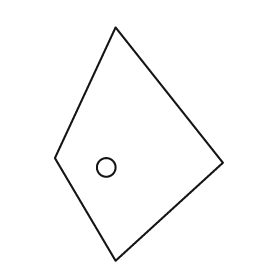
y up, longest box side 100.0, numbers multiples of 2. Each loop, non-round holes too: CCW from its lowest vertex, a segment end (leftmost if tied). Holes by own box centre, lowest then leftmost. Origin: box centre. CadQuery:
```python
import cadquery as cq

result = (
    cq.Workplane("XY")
    .moveTo(-10.0, -50.0)
    .lineTo(36.0, -8.0)
    .lineTo(-10.0, 50.0)
    .lineTo(-36.0, -6.0)
    .close()
    .moveTo(-14.0, -10.0)
    .circle(4.0)
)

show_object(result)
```